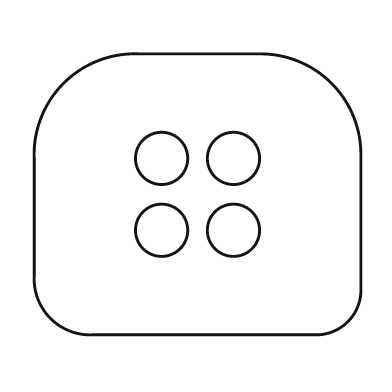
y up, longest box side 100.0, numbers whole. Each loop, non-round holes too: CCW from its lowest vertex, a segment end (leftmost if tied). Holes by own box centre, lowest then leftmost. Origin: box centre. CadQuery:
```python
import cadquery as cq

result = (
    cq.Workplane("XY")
    .moveTo(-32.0, -43.0)
    .lineTo(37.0, -43.0)
    .threePointArc((46.0, -39.0), (50.0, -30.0))
    .lineTo(50.0, 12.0)
    .threePointArc((41.0, 34.0), (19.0, 43.0))
    .lineTo(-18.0, 43.0)
    .threePointArc((-41.0, 34.0), (-50.0, 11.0))
    .lineTo(-50.0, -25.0)
    .threePointArc((-45.0, -38.0), (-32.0, -43.0))
    .close()
    .moveTo(-11.0, -11.0)
    .circle(8.0)
    .moveTo(11.0, -11.0)
    .circle(8.0)
    .moveTo(-11.0, 11.0)
    .circle(8.0)
    .moveTo(11.0, 11.0)
    .circle(8.0)
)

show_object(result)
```